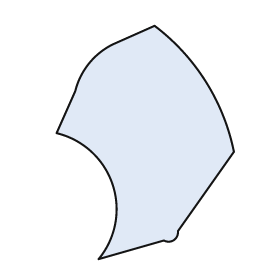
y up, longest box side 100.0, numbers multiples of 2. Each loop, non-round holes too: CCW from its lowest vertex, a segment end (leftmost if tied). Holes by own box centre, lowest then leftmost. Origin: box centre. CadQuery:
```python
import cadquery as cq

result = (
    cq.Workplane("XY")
    .moveTo(-20.0, -50.0)
    .lineTo(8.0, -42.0)
    .threePointArc((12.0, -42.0), (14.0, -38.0))
    .lineTo(38.0, -4.0)
    .threePointArc((26.0, 26.0), (4.0, 50.0))
    .lineTo(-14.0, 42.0)
    .threePointArc((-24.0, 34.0), (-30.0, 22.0))
    .lineTo(-38.0, 4.0)
    .threePointArc((-14.0, -18.0), (-20.0, -50.0))
    .close()
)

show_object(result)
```